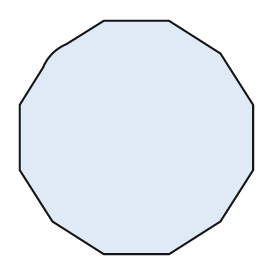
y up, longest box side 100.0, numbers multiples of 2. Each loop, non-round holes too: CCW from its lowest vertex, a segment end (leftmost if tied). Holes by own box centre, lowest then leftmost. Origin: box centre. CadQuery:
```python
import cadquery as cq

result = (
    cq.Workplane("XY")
    .moveTo(-14.0, -50.0)
    .lineTo(14.0, -50.0)
    .lineTo(36.0, -36.0)
    .lineTo(50.0, -14.0)
    .lineTo(50.0, 14.0)
    .lineTo(36.0, 36.0)
    .lineTo(14.0, 50.0)
    .lineTo(-14.0, 50.0)
    .lineTo(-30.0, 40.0)
    .threePointArc((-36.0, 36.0), (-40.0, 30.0))
    .lineTo(-50.0, 14.0)
    .lineTo(-50.0, -14.0)
    .lineTo(-36.0, -36.0)
    .close()
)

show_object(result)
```